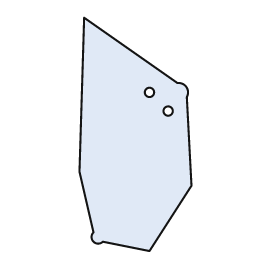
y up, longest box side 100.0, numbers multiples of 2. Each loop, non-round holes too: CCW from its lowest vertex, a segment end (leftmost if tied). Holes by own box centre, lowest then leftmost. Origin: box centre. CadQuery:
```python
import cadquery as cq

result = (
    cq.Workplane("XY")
    .moveTo(6.0, -50.0)
    .lineTo(24.0, -22.0)
    .lineTo(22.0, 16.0)
    .threePointArc((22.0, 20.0), (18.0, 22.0))
    .lineTo(-22.0, 50.0)
    .lineTo(-24.0, -16.0)
    .lineTo(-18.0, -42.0)
    .threePointArc((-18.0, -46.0), (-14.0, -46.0))
    .close()
    .moveTo(14.0, 10.0)
    .circle(2.0)
    .moveTo(6.0, 18.0)
    .circle(2.0)
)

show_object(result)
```